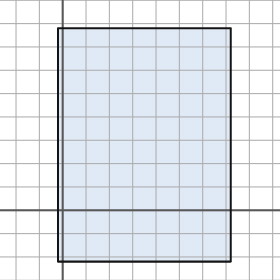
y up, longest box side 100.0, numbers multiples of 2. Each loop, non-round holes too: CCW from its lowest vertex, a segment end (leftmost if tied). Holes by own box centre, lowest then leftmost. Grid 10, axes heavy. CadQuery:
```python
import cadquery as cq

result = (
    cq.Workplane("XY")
    .moveTo(-2.0, -22.0)
    .lineTo(72.0, -22.0)
    .lineTo(72.0, 78.0)
    .lineTo(-2.0, 78.0)
    .close()
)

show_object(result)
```